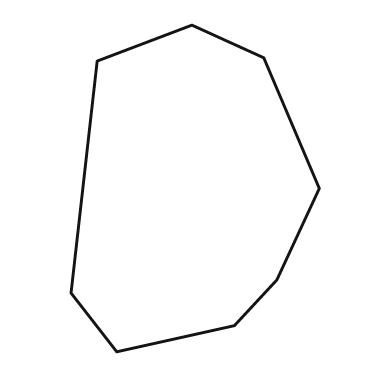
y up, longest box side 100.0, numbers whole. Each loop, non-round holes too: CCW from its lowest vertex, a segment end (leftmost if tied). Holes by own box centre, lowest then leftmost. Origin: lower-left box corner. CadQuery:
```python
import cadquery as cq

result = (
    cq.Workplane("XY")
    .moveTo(14.0, 0.0)
    .lineTo(50.0, 8.0)
    .lineTo(63.0, 22.0)
    .lineTo(76.0, 50.0)
    .lineTo(59.0, 90.0)
    .lineTo(37.0, 100.0)
    .lineTo(8.0, 89.0)
    .lineTo(0.0, 18.0)
    .close()
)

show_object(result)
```